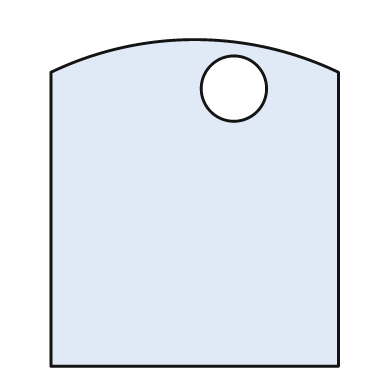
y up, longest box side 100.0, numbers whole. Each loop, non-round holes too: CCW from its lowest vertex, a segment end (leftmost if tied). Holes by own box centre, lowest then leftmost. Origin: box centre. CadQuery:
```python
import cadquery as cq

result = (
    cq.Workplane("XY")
    .moveTo(-44.0, -50.0)
    .lineTo(44.0, -50.0)
    .lineTo(44.0, 40.0)
    .threePointArc((0.0, 50.0), (-44.0, 40.0))
    .close()
    .moveTo(12.0, 35.0)
    .circle(10.0)
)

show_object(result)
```